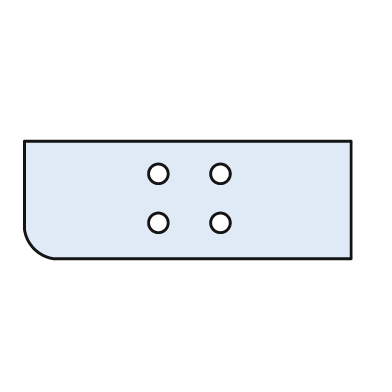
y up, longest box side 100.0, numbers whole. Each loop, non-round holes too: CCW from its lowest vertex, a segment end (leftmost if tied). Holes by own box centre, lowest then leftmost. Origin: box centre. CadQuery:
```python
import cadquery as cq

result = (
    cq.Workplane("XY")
    .moveTo(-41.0, -18.0)
    .lineTo(50.0, -18.0)
    .lineTo(50.0, 18.0)
    .lineTo(-50.0, 18.0)
    .lineTo(-50.0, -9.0)
    .threePointArc((-47.0, -15.0), (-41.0, -18.0))
    .close()
    .moveTo(-9.0, -7.0)
    .circle(3.0)
    .moveTo(10.0, -7.0)
    .circle(3.0)
    .moveTo(-9.0, 8.0)
    .circle(3.0)
    .moveTo(10.0, 8.0)
    .circle(3.0)
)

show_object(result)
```